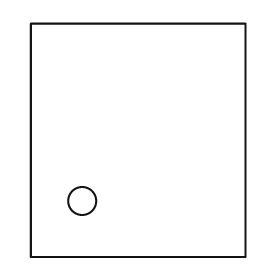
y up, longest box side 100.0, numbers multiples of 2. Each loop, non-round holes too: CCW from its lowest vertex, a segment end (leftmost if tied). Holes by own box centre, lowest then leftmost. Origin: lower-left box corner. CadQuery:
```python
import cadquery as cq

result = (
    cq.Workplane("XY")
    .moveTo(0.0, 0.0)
    .lineTo(92.0, 0.0)
    .lineTo(92.0, 100.0)
    .lineTo(0.0, 100.0)
    .close()
    .moveTo(22.0, 24.0)
    .circle(6.0)
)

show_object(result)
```